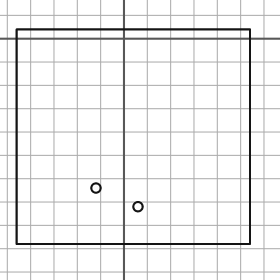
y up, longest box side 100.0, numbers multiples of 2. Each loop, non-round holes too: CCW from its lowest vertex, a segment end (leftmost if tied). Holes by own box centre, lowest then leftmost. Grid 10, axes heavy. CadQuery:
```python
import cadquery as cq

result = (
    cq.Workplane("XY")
    .moveTo(-46.0, -88.0)
    .lineTo(54.0, -88.0)
    .lineTo(54.0, 4.0)
    .lineTo(-46.0, 4.0)
    .close()
    .moveTo(6.0, -72.0)
    .circle(2.0)
    .moveTo(-12.0, -64.0)
    .circle(2.0)
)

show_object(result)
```